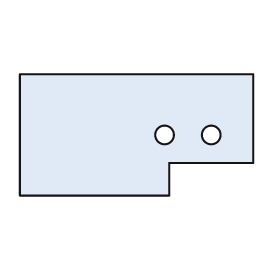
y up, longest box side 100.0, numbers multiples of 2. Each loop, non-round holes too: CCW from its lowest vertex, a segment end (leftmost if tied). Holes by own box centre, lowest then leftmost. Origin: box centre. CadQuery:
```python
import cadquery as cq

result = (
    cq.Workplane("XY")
    .moveTo(-50.0, -26.0)
    .lineTo(14.0, -26.0)
    .lineTo(14.0, -12.0)
    .lineTo(50.0, -12.0)
    .lineTo(50.0, 26.0)
    .lineTo(-50.0, 26.0)
    .close()
    .moveTo(12.0, 0.0)
    .circle(4.0)
    .moveTo(32.0, 0.0)
    .circle(4.0)
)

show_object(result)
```